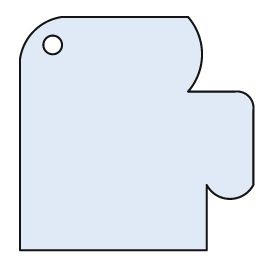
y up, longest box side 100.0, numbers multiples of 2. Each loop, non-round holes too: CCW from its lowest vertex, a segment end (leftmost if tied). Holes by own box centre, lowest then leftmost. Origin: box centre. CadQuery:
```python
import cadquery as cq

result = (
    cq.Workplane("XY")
    .moveTo(-50.0, -50.0)
    .lineTo(30.0, -50.0)
    .lineTo(30.0, -22.0)
    .threePointArc((40.0, -28.0), (50.0, -22.0))
    .lineTo(50.0, 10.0)
    .threePointArc((48.0, 16.0), (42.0, 18.0))
    .lineTo(22.0, 18.0)
    .threePointArc((28.0, 34.0), (22.0, 50.0))
    .lineTo(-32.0, 50.0)
    .threePointArc((-44.0, 44.0), (-50.0, 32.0))
    .close()
    .moveTo(-36.0, 38.0)
    .circle(4.0)
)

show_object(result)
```